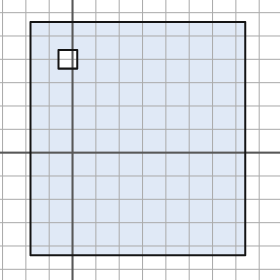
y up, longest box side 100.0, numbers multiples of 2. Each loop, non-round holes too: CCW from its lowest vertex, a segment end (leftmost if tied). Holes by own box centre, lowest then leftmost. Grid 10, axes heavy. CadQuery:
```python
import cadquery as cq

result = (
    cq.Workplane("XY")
    .moveTo(-18.0, -44.0)
    .lineTo(74.0, -44.0)
    .lineTo(74.0, 56.0)
    .lineTo(-18.0, 56.0)
    .close()
    .moveTo(-6.0, 36.0)
    .lineTo(2.0, 36.0)
    .lineTo(2.0, 44.0)
    .lineTo(-6.0, 44.0)
    .close()
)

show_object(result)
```